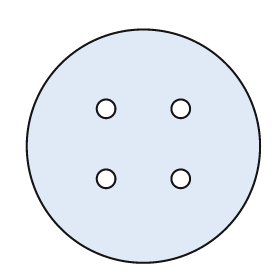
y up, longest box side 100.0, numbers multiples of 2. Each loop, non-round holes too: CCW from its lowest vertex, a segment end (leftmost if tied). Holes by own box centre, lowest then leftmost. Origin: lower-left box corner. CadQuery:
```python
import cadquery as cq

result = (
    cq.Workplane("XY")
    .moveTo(50.0, 50.0)
    .circle(50.0)
    .moveTo(34.0, 36.0)
    .circle(4.0)
    .moveTo(66.0, 36.0)
    .circle(4.0)
    .moveTo(34.0, 66.0)
    .circle(4.0)
    .moveTo(66.0, 66.0)
    .circle(4.0)
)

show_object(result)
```